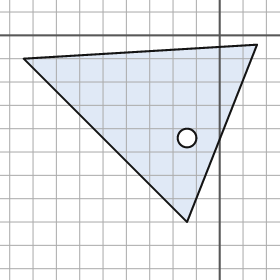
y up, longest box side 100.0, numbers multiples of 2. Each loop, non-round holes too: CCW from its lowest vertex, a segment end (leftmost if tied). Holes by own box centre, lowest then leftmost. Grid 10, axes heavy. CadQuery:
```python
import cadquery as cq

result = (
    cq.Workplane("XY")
    .moveTo(-14.0, -80.0)
    .lineTo(16.0, -4.0)
    .lineTo(-84.0, -10.0)
    .close()
    .moveTo(-14.0, -44.0)
    .circle(4.0)
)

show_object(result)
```